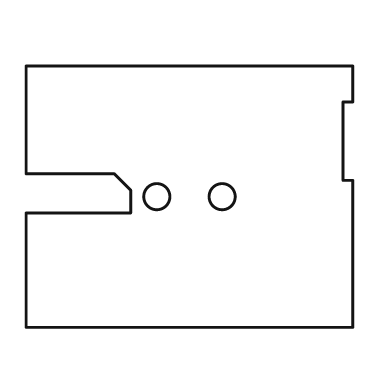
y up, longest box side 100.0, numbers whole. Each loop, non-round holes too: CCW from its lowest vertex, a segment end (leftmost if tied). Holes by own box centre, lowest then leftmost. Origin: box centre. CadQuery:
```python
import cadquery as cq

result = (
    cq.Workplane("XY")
    .moveTo(-50.0, -40.0)
    .lineTo(50.0, -40.0)
    .lineTo(50.0, 5.0)
    .lineTo(47.0, 5.0)
    .lineTo(47.0, 29.0)
    .lineTo(50.0, 29.0)
    .lineTo(50.0, 40.0)
    .lineTo(-50.0, 40.0)
    .lineTo(-50.0, 7.0)
    .lineTo(-23.0, 7.0)
    .lineTo(-18.0, 2.0)
    .lineTo(-18.0, -5.0)
    .lineTo(-50.0, -5.0)
    .close()
    .moveTo(-10.0, 0.0)
    .circle(4.0)
    .moveTo(10.0, 0.0)
    .circle(4.0)
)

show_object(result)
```